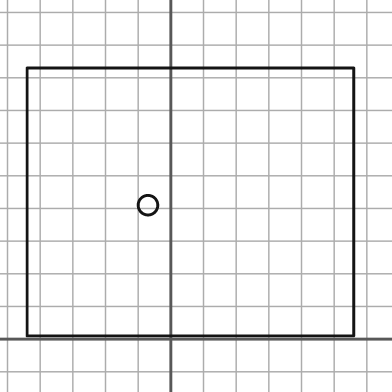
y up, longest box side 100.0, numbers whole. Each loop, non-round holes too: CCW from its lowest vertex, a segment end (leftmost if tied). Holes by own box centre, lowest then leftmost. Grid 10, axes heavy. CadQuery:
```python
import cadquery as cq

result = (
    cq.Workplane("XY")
    .moveTo(-44.0, 1.0)
    .lineTo(56.0, 1.0)
    .lineTo(56.0, 83.0)
    .lineTo(-44.0, 83.0)
    .close()
    .moveTo(-7.0, 41.0)
    .circle(3.0)
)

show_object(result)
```